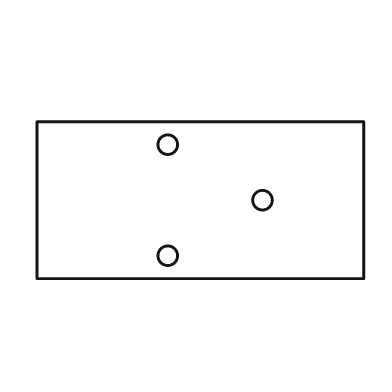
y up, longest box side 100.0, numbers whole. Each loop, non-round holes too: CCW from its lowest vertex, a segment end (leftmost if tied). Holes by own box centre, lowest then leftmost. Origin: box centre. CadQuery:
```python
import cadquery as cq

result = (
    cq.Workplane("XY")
    .moveTo(-50.0, -24.0)
    .lineTo(50.0, -24.0)
    .lineTo(50.0, 24.0)
    .lineTo(-50.0, 24.0)
    .close()
    .moveTo(-10.0, -17.0)
    .circle(3.0)
    .moveTo(19.0, 0.0)
    .circle(3.0)
    .moveTo(-10.0, 17.0)
    .circle(3.0)
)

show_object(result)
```